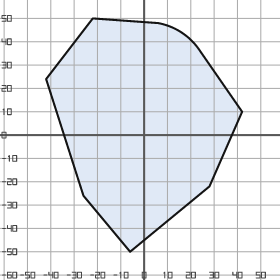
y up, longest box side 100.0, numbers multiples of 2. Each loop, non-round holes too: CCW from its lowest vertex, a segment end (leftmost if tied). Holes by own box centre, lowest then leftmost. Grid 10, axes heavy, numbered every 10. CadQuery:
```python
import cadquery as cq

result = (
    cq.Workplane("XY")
    .moveTo(-6.0, -50.0)
    .lineTo(28.0, -22.0)
    .lineTo(42.0, 10.0)
    .lineTo(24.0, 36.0)
    .threePointArc((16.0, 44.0), (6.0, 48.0))
    .lineTo(-22.0, 50.0)
    .lineTo(-42.0, 24.0)
    .lineTo(-26.0, -26.0)
    .close()
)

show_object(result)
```